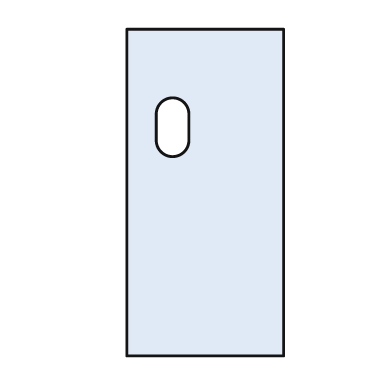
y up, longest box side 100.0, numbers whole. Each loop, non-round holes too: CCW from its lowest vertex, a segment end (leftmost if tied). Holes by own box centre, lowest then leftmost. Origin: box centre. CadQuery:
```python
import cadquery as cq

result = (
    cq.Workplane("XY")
    .moveTo(-24.0, -50.0)
    .lineTo(24.0, -50.0)
    .lineTo(24.0, 50.0)
    .lineTo(-24.0, 50.0)
    .close()
    .moveTo(-15.0, 16.0)
    .threePointArc((-10.0, 11.0), (-5.0, 16.0))
    .lineTo(-5.0, 24.0)
    .threePointArc((-10.0, 29.0), (-15.0, 24.0))
    .close()
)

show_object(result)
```